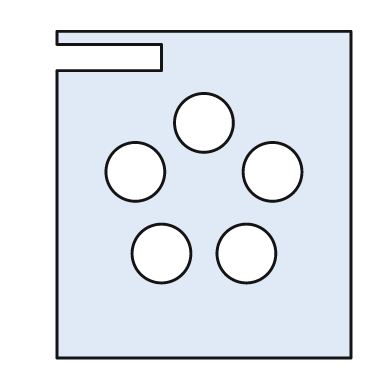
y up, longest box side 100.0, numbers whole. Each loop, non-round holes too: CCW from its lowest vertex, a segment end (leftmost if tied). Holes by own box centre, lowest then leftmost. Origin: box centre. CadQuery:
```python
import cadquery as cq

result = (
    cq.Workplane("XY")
    .moveTo(-45.0, -50.0)
    .lineTo(45.0, -50.0)
    .lineTo(45.0, 50.0)
    .lineTo(-45.0, 50.0)
    .lineTo(-45.0, 46.0)
    .lineTo(-13.0, 46.0)
    .lineTo(-13.0, 38.0)
    .lineTo(-45.0, 38.0)
    .close()
    .moveTo(-13.0, -18.0)
    .circle(9.0)
    .moveTo(13.0, -18.0)
    .circle(9.0)
    .moveTo(-21.0, 7.0)
    .circle(9.0)
    .moveTo(21.0, 7.0)
    .circle(9.0)
    .moveTo(0.0, 22.0)
    .circle(9.0)
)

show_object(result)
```